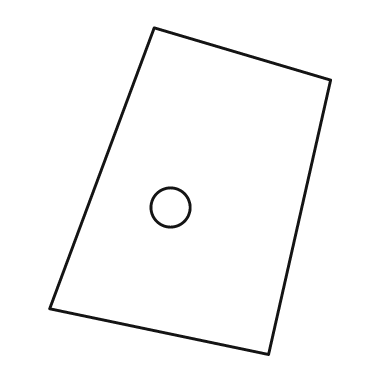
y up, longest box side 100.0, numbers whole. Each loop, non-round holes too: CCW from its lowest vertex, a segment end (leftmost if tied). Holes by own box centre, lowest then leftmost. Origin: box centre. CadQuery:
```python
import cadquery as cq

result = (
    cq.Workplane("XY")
    .moveTo(24.0, -50.0)
    .lineTo(43.0, 34.0)
    .lineTo(-11.0, 50.0)
    .lineTo(-43.0, -36.0)
    .close()
    .moveTo(-6.0, -5.0)
    .circle(6.0)
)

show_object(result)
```